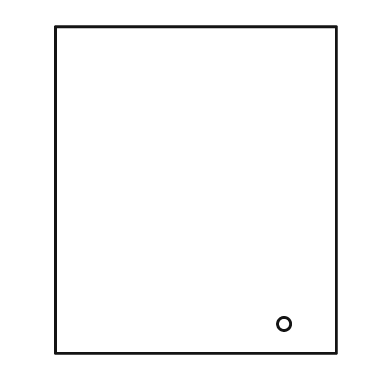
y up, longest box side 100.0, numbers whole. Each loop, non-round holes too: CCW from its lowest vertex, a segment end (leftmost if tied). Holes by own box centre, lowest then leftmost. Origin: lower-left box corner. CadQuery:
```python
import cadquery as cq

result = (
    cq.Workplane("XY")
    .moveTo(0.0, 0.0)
    .lineTo(86.0, 0.0)
    .lineTo(86.0, 100.0)
    .lineTo(0.0, 100.0)
    .close()
    .moveTo(70.0, 9.0)
    .circle(2.0)
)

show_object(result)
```